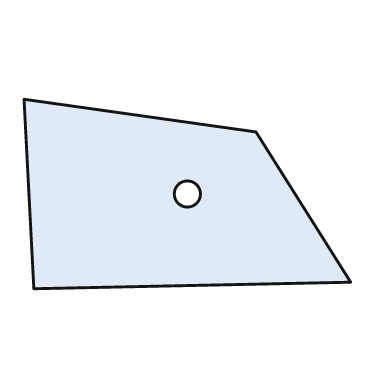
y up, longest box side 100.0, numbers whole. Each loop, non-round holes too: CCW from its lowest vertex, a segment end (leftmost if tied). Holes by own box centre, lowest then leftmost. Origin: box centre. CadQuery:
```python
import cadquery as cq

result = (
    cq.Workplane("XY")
    .moveTo(-47.0, -29.0)
    .lineTo(50.0, -27.0)
    .lineTo(21.0, 19.0)
    .lineTo(-50.0, 29.0)
    .close()
    .moveTo(0.0, 0.0)
    .circle(4.0)
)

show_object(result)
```